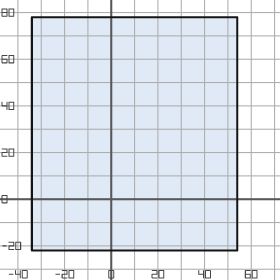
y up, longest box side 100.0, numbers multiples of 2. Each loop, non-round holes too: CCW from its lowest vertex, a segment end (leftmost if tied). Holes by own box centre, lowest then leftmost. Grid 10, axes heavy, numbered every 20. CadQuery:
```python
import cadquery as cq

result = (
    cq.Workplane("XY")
    .moveTo(-34.0, -22.0)
    .lineTo(54.0, -22.0)
    .lineTo(54.0, 78.0)
    .lineTo(-34.0, 78.0)
    .close()
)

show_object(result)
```